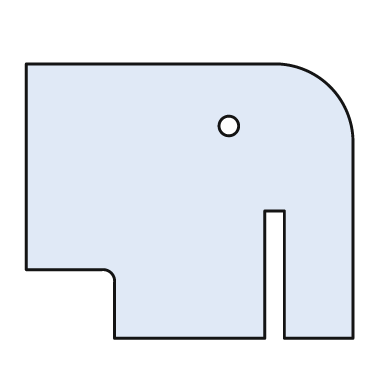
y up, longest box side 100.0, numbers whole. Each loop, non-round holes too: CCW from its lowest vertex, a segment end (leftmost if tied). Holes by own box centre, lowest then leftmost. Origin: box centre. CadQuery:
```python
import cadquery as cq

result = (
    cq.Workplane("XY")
    .moveTo(-23.0, -42.0)
    .lineTo(23.0, -42.0)
    .lineTo(23.0, -3.0)
    .lineTo(29.0, -3.0)
    .lineTo(29.0, -42.0)
    .lineTo(50.0, -42.0)
    .lineTo(50.0, 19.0)
    .threePointArc((43.0, 35.0), (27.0, 42.0))
    .lineTo(-50.0, 42.0)
    .lineTo(-50.0, -21.0)
    .lineTo(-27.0, -21.0)
    .threePointArc((-24.0, -22.0), (-23.0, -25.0))
    .close()
    .moveTo(12.0, 23.0)
    .circle(3.0)
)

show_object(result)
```